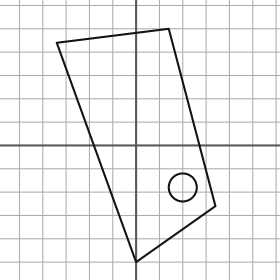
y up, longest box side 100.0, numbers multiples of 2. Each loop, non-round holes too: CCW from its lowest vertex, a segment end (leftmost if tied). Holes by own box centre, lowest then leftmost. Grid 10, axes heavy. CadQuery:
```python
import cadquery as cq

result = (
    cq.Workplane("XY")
    .moveTo(0.0, -50.0)
    .lineTo(34.0, -26.0)
    .lineTo(14.0, 50.0)
    .lineTo(-34.0, 44.0)
    .close()
    .moveTo(20.0, -18.0)
    .circle(6.0)
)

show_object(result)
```